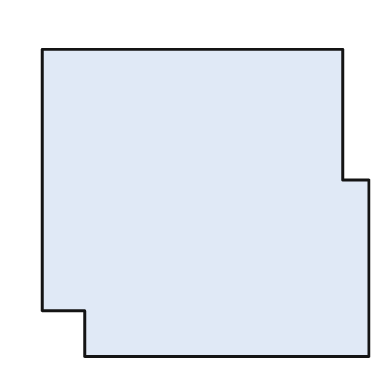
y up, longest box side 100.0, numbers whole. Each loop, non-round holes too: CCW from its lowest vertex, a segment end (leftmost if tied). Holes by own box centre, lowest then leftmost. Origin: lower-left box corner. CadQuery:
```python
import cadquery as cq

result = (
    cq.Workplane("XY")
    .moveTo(13.0, 0.0)
    .lineTo(100.0, 0.0)
    .lineTo(100.0, 54.0)
    .lineTo(92.0, 54.0)
    .lineTo(92.0, 94.0)
    .lineTo(0.0, 94.0)
    .lineTo(0.0, 14.0)
    .lineTo(13.0, 14.0)
    .close()
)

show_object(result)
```